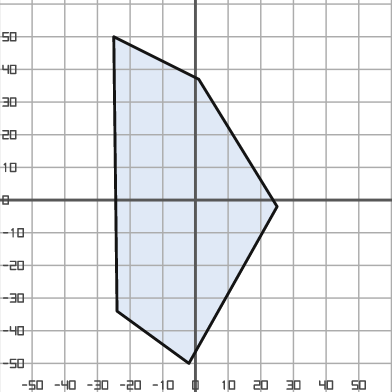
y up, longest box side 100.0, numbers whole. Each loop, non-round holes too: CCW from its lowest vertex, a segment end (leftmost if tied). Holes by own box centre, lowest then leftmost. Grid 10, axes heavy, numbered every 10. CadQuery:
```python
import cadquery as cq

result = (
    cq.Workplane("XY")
    .moveTo(-2.0, -50.0)
    .lineTo(25.0, -2.0)
    .lineTo(1.0, 37.0)
    .lineTo(-25.0, 50.0)
    .lineTo(-24.0, -34.0)
    .close()
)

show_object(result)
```